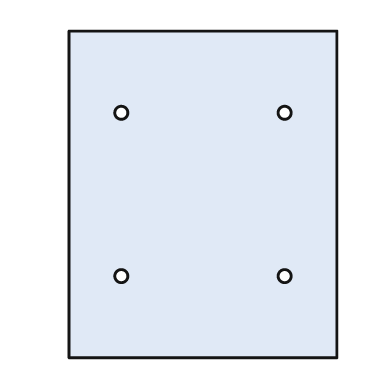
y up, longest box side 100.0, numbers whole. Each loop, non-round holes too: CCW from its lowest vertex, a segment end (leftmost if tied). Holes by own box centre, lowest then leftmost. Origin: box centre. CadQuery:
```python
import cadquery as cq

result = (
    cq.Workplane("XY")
    .moveTo(-41.0, -50.0)
    .lineTo(41.0, -50.0)
    .lineTo(41.0, 50.0)
    .lineTo(-41.0, 50.0)
    .close()
    .moveTo(-25.0, -25.0)
    .circle(2.0)
    .moveTo(25.0, -25.0)
    .circle(2.0)
    .moveTo(-25.0, 25.0)
    .circle(2.0)
    .moveTo(25.0, 25.0)
    .circle(2.0)
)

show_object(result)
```